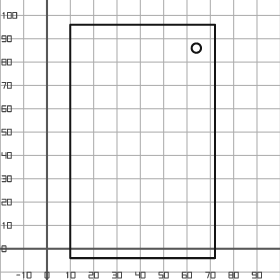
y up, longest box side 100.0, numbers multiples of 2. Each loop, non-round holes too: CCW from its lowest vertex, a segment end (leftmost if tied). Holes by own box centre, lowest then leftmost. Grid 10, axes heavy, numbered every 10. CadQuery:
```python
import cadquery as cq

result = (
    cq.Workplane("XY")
    .moveTo(10.0, -4.0)
    .lineTo(72.0, -4.0)
    .lineTo(72.0, 96.0)
    .lineTo(10.0, 96.0)
    .close()
    .moveTo(64.0, 86.0)
    .circle(2.0)
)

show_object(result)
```